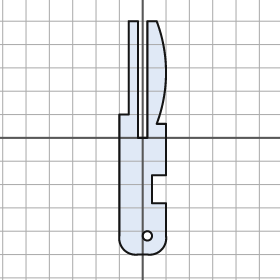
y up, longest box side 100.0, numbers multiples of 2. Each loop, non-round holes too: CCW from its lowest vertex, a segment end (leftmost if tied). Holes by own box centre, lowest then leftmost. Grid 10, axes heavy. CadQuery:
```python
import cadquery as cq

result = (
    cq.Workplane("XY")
    .moveTo(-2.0, -50.0)
    .lineTo(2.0, -50.0)
    .threePointArc((8.0, -48.0), (10.0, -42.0))
    .lineTo(10.0, -28.0)
    .lineTo(4.0, -28.0)
    .lineTo(4.0, -16.0)
    .lineTo(10.0, -16.0)
    .lineTo(10.0, 6.0)
    .lineTo(6.0, 6.0)
    .threePointArc((10.0, 28.0), (6.0, 50.0))
    .lineTo(2.0, 50.0)
    .lineTo(2.0, 0.0)
    .lineTo(-2.0, 0.0)
    .lineTo(-2.0, 50.0)
    .lineTo(-6.0, 50.0)
    .lineTo(-6.0, 10.0)
    .lineTo(-10.0, 10.0)
    .lineTo(-10.0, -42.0)
    .threePointArc((-8.0, -48.0), (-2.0, -50.0))
    .close()
    .moveTo(2.0, -42.0)
    .circle(2.0)
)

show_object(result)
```